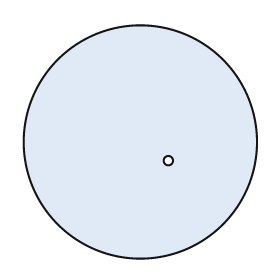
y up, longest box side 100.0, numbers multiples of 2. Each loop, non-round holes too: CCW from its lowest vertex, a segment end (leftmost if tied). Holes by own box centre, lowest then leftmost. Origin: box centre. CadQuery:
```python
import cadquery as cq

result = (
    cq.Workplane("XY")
    .moveTo(0.0, 0.0)
    .circle(50.0)
    .moveTo(12.0, -8.0)
    .circle(2.0)
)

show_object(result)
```